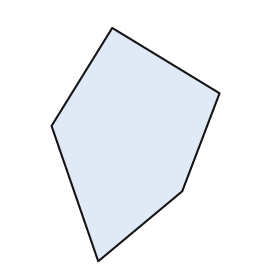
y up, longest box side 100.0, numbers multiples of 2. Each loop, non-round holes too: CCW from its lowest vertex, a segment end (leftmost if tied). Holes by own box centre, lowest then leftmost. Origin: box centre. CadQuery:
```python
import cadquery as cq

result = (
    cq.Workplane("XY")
    .moveTo(-16.0, -50.0)
    .lineTo(20.0, -20.0)
    .lineTo(36.0, 22.0)
    .lineTo(-10.0, 50.0)
    .lineTo(-36.0, 8.0)
    .close()
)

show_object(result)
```